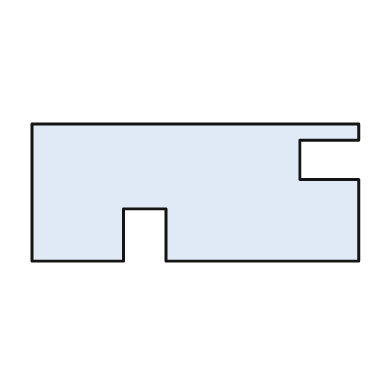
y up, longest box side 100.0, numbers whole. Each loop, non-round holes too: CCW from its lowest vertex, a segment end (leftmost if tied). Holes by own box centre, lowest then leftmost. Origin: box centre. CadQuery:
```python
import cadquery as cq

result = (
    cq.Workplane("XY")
    .moveTo(-50.0, -21.0)
    .lineTo(-22.0, -21.0)
    .lineTo(-22.0, -5.0)
    .lineTo(-9.0, -5.0)
    .lineTo(-9.0, -21.0)
    .lineTo(50.0, -21.0)
    .lineTo(50.0, 4.0)
    .lineTo(32.0, 4.0)
    .lineTo(32.0, 16.0)
    .lineTo(50.0, 16.0)
    .lineTo(50.0, 21.0)
    .lineTo(-50.0, 21.0)
    .close()
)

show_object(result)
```